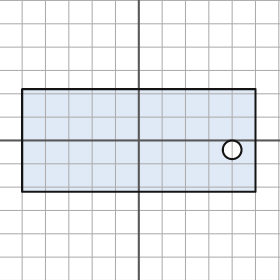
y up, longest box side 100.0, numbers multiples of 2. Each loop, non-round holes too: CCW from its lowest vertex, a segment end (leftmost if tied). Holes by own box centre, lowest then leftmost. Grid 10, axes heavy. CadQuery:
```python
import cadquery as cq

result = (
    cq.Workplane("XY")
    .moveTo(-50.0, -22.0)
    .lineTo(50.0, -22.0)
    .lineTo(50.0, 22.0)
    .lineTo(-50.0, 22.0)
    .close()
    .moveTo(40.0, -4.0)
    .circle(4.0)
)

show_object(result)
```